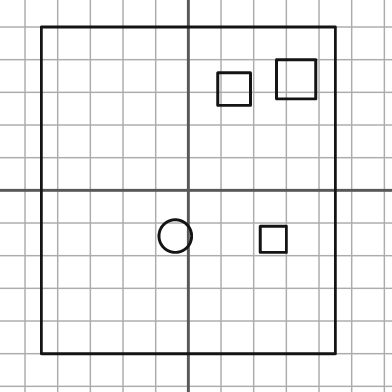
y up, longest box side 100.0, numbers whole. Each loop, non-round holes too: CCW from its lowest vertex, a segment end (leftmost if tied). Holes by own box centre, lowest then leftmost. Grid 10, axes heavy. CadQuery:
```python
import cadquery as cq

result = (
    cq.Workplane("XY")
    .moveTo(-45.0, -50.0)
    .lineTo(45.0, -50.0)
    .lineTo(45.0, 50.0)
    .lineTo(-45.0, 50.0)
    .close()
    .moveTo(22.0, -19.0)
    .lineTo(30.0, -19.0)
    .lineTo(30.0, -11.0)
    .lineTo(22.0, -11.0)
    .close()
    .moveTo(-4.0, -14.0)
    .circle(5.0)
    .moveTo(9.0, 26.0)
    .lineTo(19.0, 26.0)
    .lineTo(19.0, 36.0)
    .lineTo(9.0, 36.0)
    .close()
    .moveTo(27.0, 28.0)
    .lineTo(39.0, 28.0)
    .lineTo(39.0, 40.0)
    .lineTo(27.0, 40.0)
    .close()
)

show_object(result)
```